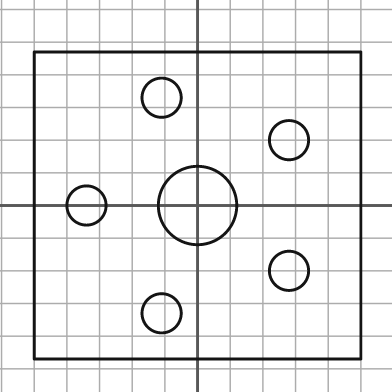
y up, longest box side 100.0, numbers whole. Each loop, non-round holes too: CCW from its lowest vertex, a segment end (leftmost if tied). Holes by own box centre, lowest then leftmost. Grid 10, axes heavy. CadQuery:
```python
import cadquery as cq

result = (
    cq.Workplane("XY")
    .moveTo(-50.0, -47.0)
    .lineTo(50.0, -47.0)
    .lineTo(50.0, 47.0)
    .lineTo(-50.0, 47.0)
    .close()
    .moveTo(-11.0, -33.0)
    .circle(6.0)
    .moveTo(28.0, -20.0)
    .circle(6.0)
    .moveTo(-34.0, 0.0)
    .circle(6.0)
    .moveTo(0.0, 0.0)
    .circle(12.0)
    .moveTo(28.0, 20.0)
    .circle(6.0)
    .moveTo(-11.0, 33.0)
    .circle(6.0)
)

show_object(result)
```